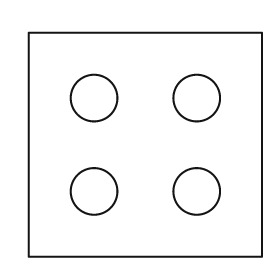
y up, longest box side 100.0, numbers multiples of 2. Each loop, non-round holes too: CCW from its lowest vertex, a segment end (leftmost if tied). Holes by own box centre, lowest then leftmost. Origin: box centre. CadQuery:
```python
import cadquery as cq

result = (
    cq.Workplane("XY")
    .moveTo(-50.0, -48.0)
    .lineTo(50.0, -48.0)
    .lineTo(50.0, 48.0)
    .lineTo(-50.0, 48.0)
    .close()
    .moveTo(-22.0, -20.0)
    .circle(10.0)
    .moveTo(22.0, -20.0)
    .circle(10.0)
    .moveTo(-22.0, 20.0)
    .circle(10.0)
    .moveTo(22.0, 20.0)
    .circle(10.0)
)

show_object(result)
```